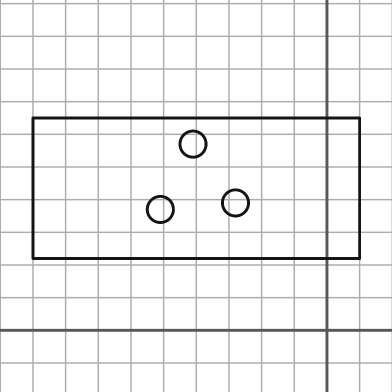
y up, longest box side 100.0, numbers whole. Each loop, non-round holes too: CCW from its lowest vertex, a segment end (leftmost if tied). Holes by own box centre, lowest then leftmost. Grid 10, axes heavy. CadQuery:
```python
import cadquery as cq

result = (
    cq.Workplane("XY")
    .moveTo(-90.0, 22.0)
    .lineTo(10.0, 22.0)
    .lineTo(10.0, 65.0)
    .lineTo(-90.0, 65.0)
    .close()
    .moveTo(-51.0, 37.0)
    .circle(4.0)
    .moveTo(-28.0, 39.0)
    .circle(4.0)
    .moveTo(-41.0, 57.0)
    .circle(4.0)
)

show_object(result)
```